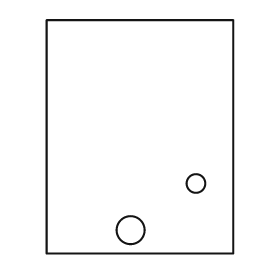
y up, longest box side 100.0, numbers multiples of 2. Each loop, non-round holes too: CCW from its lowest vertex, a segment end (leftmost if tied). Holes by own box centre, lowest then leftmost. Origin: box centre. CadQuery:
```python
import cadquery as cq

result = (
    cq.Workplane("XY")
    .moveTo(-40.0, -50.0)
    .lineTo(40.0, -50.0)
    .lineTo(40.0, 50.0)
    .lineTo(-40.0, 50.0)
    .close()
    .moveTo(-4.0, -40.0)
    .circle(6.0)
    .moveTo(24.0, -20.0)
    .circle(4.0)
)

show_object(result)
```